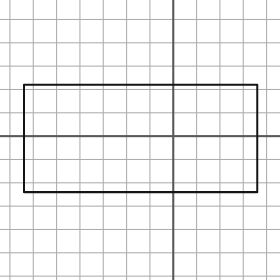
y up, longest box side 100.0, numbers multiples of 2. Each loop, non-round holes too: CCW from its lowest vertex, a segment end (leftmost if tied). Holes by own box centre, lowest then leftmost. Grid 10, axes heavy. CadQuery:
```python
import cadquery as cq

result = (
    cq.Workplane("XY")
    .moveTo(-64.0, -24.0)
    .lineTo(36.0, -24.0)
    .lineTo(36.0, 22.0)
    .lineTo(-64.0, 22.0)
    .close()
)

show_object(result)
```